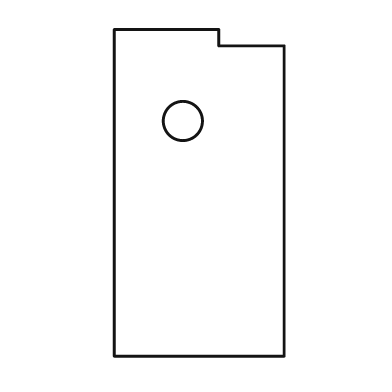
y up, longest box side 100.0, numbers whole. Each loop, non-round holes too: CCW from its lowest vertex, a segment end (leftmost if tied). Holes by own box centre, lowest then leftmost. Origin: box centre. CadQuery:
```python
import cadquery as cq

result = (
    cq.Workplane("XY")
    .moveTo(-26.0, -50.0)
    .lineTo(26.0, -50.0)
    .lineTo(26.0, 45.0)
    .lineTo(6.0, 45.0)
    .lineTo(6.0, 50.0)
    .lineTo(-26.0, 50.0)
    .close()
    .moveTo(-5.0, 22.0)
    .circle(6.0)
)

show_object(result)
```